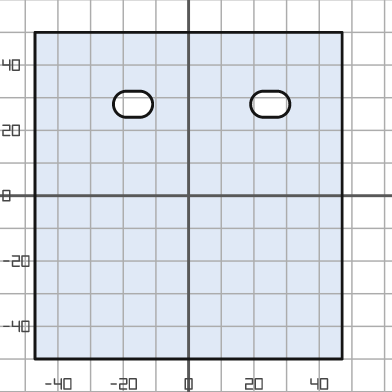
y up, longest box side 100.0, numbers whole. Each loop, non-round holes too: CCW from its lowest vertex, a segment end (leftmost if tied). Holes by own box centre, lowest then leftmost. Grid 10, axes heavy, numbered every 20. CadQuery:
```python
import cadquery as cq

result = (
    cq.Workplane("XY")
    .moveTo(-47.0, -50.0)
    .lineTo(47.0, -50.0)
    .lineTo(47.0, 50.0)
    .lineTo(-47.0, 50.0)
    .close()
    .moveTo(-19.0, 24.0)
    .lineTo(-15.0, 24.0)
    .threePointArc((-11.0, 28.0), (-15.0, 32.0))
    .lineTo(-19.0, 32.0)
    .threePointArc((-23.0, 28.0), (-19.0, 24.0))
    .close()
    .moveTo(23.0, 24.0)
    .lineTo(27.0, 24.0)
    .threePointArc((31.0, 28.0), (27.0, 32.0))
    .lineTo(23.0, 32.0)
    .threePointArc((19.0, 28.0), (23.0, 24.0))
    .close()
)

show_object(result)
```